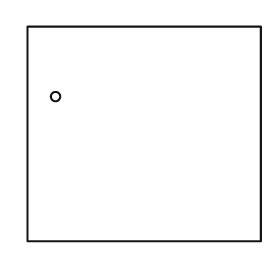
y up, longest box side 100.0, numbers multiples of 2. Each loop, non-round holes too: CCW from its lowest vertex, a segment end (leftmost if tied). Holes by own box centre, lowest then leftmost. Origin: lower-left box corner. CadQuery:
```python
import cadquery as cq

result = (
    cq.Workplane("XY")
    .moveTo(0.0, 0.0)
    .lineTo(100.0, 0.0)
    .lineTo(100.0, 92.0)
    .lineTo(0.0, 92.0)
    .close()
    .moveTo(12.0, 62.0)
    .circle(2.0)
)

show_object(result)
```